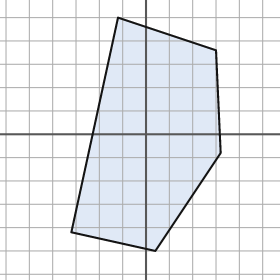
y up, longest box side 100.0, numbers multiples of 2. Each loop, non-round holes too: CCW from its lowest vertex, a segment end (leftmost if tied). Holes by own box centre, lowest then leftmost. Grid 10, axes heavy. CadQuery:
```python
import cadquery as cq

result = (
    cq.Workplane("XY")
    .moveTo(4.0, -50.0)
    .lineTo(32.0, -8.0)
    .lineTo(30.0, 36.0)
    .lineTo(-12.0, 50.0)
    .lineTo(-32.0, -42.0)
    .close()
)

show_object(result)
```